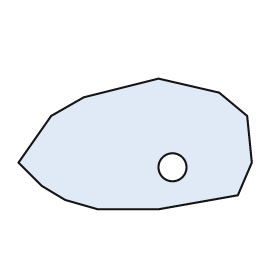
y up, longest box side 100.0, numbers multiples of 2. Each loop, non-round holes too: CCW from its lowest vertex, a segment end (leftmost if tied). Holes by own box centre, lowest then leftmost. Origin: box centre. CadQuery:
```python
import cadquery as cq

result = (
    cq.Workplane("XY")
    .moveTo(-16.0, -28.0)
    .lineTo(10.0, -28.0)
    .lineTo(44.0, -22.0)
    .lineTo(50.0, -8.0)
    .lineTo(48.0, 12.0)
    .lineTo(36.0, 22.0)
    .lineTo(10.0, 28.0)
    .lineTo(-22.0, 20.0)
    .lineTo(-36.0, 12.0)
    .lineTo(-50.0, -8.0)
    .lineTo(-40.0, -18.0)
    .lineTo(-30.0, -24.0)
    .close()
    .moveTo(16.0, -10.0)
    .circle(6.0)
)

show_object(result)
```